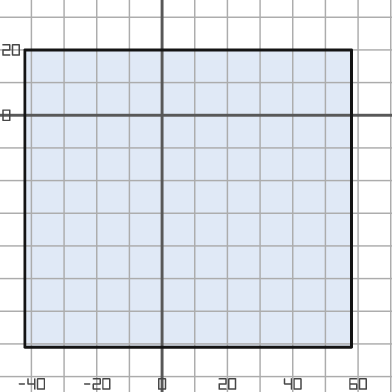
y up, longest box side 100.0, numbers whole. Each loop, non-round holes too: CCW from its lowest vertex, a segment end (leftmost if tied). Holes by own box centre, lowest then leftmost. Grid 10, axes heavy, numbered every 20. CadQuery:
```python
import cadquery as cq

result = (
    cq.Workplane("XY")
    .moveTo(-42.0, -71.0)
    .lineTo(58.0, -71.0)
    .lineTo(58.0, 20.0)
    .lineTo(-42.0, 20.0)
    .close()
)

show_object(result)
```